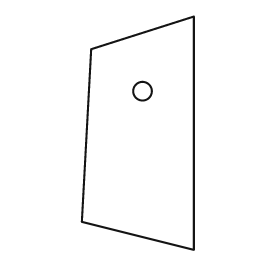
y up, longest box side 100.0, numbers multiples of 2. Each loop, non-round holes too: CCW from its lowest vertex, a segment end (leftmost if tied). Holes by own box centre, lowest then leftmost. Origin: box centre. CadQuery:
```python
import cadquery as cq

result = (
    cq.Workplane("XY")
    .moveTo(24.0, -50.0)
    .lineTo(24.0, 50.0)
    .lineTo(-20.0, 36.0)
    .lineTo(-24.0, -38.0)
    .close()
    .moveTo(2.0, 18.0)
    .circle(4.0)
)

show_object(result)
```